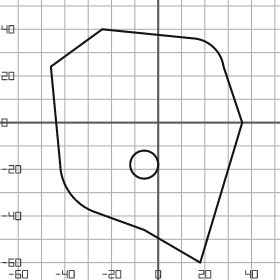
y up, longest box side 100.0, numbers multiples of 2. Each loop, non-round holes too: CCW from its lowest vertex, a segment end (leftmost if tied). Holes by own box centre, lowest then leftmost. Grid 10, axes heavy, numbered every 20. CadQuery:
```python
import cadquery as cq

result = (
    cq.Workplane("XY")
    .moveTo(18.0, -60.0)
    .lineTo(36.0, 0.0)
    .lineTo(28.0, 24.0)
    .threePointArc((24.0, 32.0), (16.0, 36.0))
    .lineTo(-24.0, 40.0)
    .lineTo(-46.0, 24.0)
    .lineTo(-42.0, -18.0)
    .threePointArc((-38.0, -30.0), (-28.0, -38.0))
    .lineTo(-6.0, -46.0)
    .close()
    .moveTo(-6.0, -18.0)
    .circle(6.0)
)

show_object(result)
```